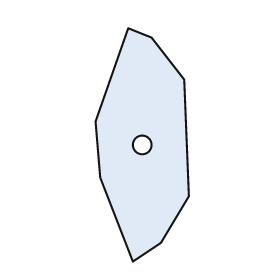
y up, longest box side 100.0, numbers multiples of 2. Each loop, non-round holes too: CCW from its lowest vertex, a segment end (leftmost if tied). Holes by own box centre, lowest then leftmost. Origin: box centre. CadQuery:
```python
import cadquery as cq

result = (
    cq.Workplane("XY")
    .moveTo(-4.0, -50.0)
    .lineTo(8.0, -42.0)
    .lineTo(20.0, -22.0)
    .lineTo(18.0, 28.0)
    .lineTo(4.0, 46.0)
    .lineTo(-6.0, 50.0)
    .lineTo(-20.0, 10.0)
    .lineTo(-18.0, -14.0)
    .close()
    .moveTo(0.0, 0.0)
    .circle(4.0)
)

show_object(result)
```